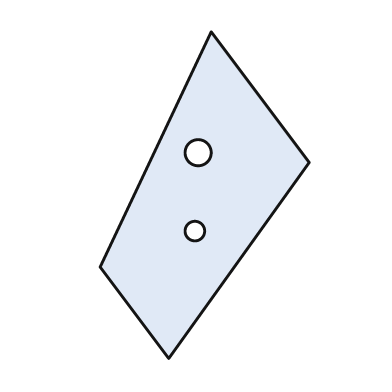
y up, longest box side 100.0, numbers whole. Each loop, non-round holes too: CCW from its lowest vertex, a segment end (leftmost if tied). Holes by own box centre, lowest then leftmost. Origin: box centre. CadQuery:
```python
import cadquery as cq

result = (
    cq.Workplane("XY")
    .moveTo(-11.0, -50.0)
    .lineTo(32.0, 10.0)
    .lineTo(2.0, 50.0)
    .lineTo(-32.0, -22.0)
    .close()
    .moveTo(-3.0, -11.0)
    .circle(3.0)
    .moveTo(-2.0, 13.0)
    .circle(4.0)
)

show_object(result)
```